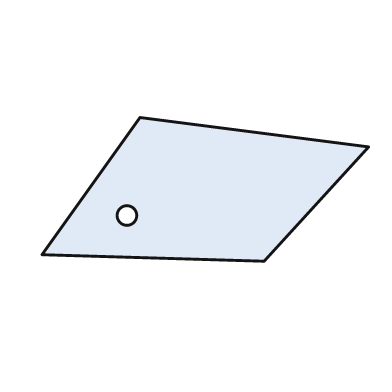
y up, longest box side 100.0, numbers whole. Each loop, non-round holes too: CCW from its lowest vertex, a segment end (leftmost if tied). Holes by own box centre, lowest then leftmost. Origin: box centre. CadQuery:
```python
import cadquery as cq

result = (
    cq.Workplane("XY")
    .moveTo(18.0, -22.0)
    .lineTo(50.0, 13.0)
    .lineTo(-20.0, 22.0)
    .lineTo(-50.0, -20.0)
    .close()
    .moveTo(-24.0, -8.0)
    .circle(3.0)
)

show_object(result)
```